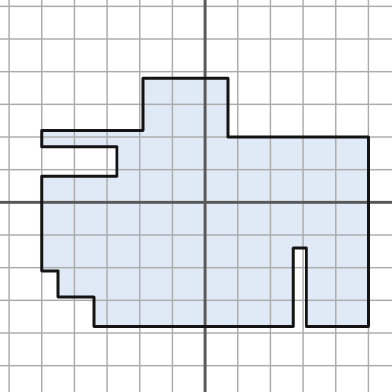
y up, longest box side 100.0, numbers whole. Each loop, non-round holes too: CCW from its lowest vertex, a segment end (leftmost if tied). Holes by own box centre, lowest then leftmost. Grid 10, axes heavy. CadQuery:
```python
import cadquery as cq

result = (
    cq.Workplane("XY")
    .moveTo(-34.0, -38.0)
    .lineTo(27.0, -38.0)
    .lineTo(27.0, -14.0)
    .lineTo(31.0, -14.0)
    .lineTo(31.0, -38.0)
    .lineTo(50.0, -38.0)
    .lineTo(50.0, 20.0)
    .lineTo(7.0, 20.0)
    .lineTo(7.0, 38.0)
    .lineTo(-19.0, 38.0)
    .lineTo(-19.0, 22.0)
    .lineTo(-50.0, 22.0)
    .lineTo(-50.0, 17.0)
    .lineTo(-27.0, 17.0)
    .lineTo(-27.0, 8.0)
    .lineTo(-50.0, 8.0)
    .lineTo(-50.0, -21.0)
    .lineTo(-45.0, -21.0)
    .lineTo(-45.0, -29.0)
    .lineTo(-34.0, -29.0)
    .close()
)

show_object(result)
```